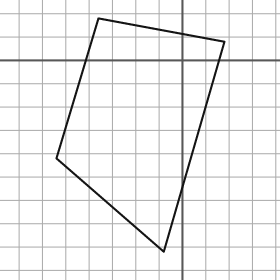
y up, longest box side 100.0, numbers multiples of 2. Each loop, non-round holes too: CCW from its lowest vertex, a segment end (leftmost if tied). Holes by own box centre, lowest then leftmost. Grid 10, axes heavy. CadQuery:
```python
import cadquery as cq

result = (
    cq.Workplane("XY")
    .moveTo(-8.0, -82.0)
    .lineTo(18.0, 8.0)
    .lineTo(-36.0, 18.0)
    .lineTo(-54.0, -42.0)
    .close()
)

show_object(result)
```